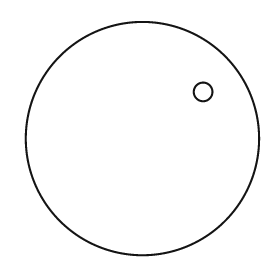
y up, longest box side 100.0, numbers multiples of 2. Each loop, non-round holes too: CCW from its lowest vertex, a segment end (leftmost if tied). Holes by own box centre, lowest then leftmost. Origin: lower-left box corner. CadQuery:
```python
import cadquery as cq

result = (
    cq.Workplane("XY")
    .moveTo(50.0, 50.0)
    .circle(50.0)
    .moveTo(76.0, 70.0)
    .circle(4.0)
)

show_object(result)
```